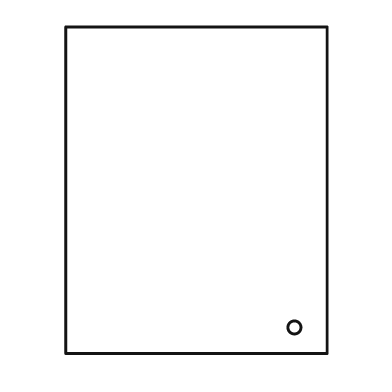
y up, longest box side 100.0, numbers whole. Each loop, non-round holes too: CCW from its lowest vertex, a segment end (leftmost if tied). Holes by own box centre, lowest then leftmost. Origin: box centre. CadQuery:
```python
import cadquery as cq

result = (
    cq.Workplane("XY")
    .moveTo(-40.0, -50.0)
    .lineTo(40.0, -50.0)
    .lineTo(40.0, 50.0)
    .lineTo(-40.0, 50.0)
    .close()
    .moveTo(30.0, -42.0)
    .circle(2.0)
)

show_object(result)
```